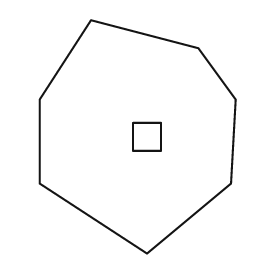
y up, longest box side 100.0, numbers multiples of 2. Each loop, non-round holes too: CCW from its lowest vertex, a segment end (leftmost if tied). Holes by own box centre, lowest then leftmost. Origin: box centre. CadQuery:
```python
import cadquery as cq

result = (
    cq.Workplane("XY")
    .moveTo(4.0, -50.0)
    .lineTo(40.0, -20.0)
    .lineTo(42.0, 16.0)
    .lineTo(26.0, 38.0)
    .lineTo(-20.0, 50.0)
    .lineTo(-42.0, 16.0)
    .lineTo(-42.0, -20.0)
    .close()
    .moveTo(-2.0, -6.0)
    .lineTo(10.0, -6.0)
    .lineTo(10.0, 6.0)
    .lineTo(-2.0, 6.0)
    .close()
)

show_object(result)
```